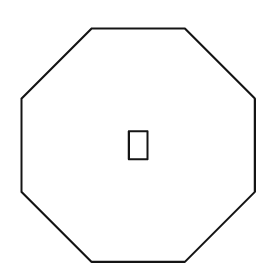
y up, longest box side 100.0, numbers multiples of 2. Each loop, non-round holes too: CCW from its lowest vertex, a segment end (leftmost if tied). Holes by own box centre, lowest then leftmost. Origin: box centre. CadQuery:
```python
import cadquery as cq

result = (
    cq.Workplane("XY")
    .moveTo(-20.0, -50.0)
    .lineTo(20.0, -50.0)
    .lineTo(50.0, -20.0)
    .lineTo(50.0, 20.0)
    .lineTo(20.0, 50.0)
    .lineTo(-20.0, 50.0)
    .lineTo(-50.0, 20.0)
    .lineTo(-50.0, -20.0)
    .close()
    .moveTo(-4.0, -6.0)
    .lineTo(4.0, -6.0)
    .lineTo(4.0, 6.0)
    .lineTo(-4.0, 6.0)
    .close()
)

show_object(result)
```